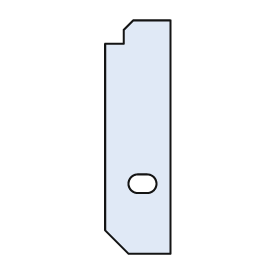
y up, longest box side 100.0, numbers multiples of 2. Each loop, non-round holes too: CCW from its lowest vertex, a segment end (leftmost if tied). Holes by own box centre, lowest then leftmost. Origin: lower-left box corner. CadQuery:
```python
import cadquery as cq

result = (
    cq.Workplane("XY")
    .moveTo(10.0, 0.0)
    .lineTo(28.0, 0.0)
    .lineTo(28.0, 100.0)
    .lineTo(12.0, 100.0)
    .lineTo(8.0, 96.0)
    .lineTo(8.0, 90.0)
    .lineTo(0.0, 90.0)
    .lineTo(0.0, 10.0)
    .close()
    .moveTo(14.0, 26.0)
    .lineTo(18.0, 26.0)
    .threePointArc((22.0, 30.0), (18.0, 34.0))
    .lineTo(14.0, 34.0)
    .threePointArc((10.0, 30.0), (14.0, 26.0))
    .close()
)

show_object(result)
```